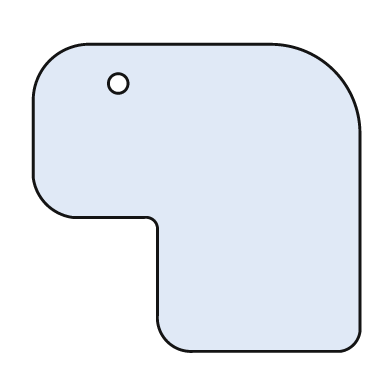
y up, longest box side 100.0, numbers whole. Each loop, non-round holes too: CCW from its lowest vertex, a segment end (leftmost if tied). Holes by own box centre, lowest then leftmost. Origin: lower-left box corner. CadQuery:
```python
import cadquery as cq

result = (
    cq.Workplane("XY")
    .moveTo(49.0, 0.0)
    .lineTo(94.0, 0.0)
    .threePointArc((98.0, 2.0), (100.0, 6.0))
    .lineTo(100.0, 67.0)
    .threePointArc((92.0, 86.0), (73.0, 94.0))
    .lineTo(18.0, 94.0)
    .threePointArc((5.0, 89.0), (0.0, 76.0))
    .lineTo(0.0, 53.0)
    .threePointArc((4.0, 45.0), (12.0, 41.0))
    .lineTo(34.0, 41.0)
    .threePointArc((37.0, 40.0), (38.0, 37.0))
    .lineTo(38.0, 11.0)
    .threePointArc((41.0, 3.0), (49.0, 0.0))
    .close()
    .moveTo(26.0, 82.0)
    .circle(3.0)
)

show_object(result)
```